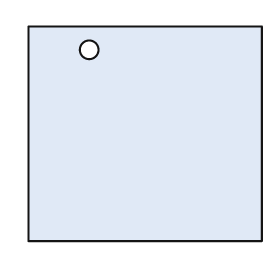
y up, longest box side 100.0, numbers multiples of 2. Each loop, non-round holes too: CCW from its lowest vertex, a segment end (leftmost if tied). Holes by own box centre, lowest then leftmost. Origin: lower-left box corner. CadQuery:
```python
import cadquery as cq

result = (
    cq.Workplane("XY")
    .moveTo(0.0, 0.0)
    .lineTo(100.0, 0.0)
    .lineTo(100.0, 92.0)
    .lineTo(0.0, 92.0)
    .close()
    .moveTo(26.0, 82.0)
    .circle(4.0)
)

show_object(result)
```